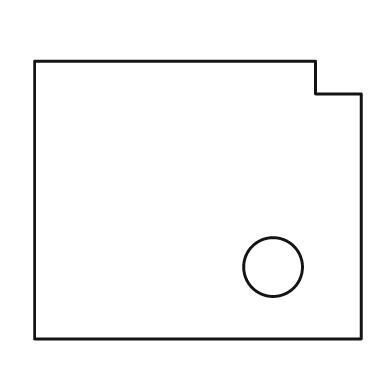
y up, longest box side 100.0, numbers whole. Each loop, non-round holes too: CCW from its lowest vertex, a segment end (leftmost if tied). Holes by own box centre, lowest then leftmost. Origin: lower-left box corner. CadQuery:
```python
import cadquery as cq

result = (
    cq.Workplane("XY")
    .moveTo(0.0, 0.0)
    .lineTo(100.0, 0.0)
    .lineTo(100.0, 75.0)
    .lineTo(86.0, 75.0)
    .lineTo(86.0, 85.0)
    .lineTo(0.0, 85.0)
    .close()
    .moveTo(73.0, 22.0)
    .circle(9.0)
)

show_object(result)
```